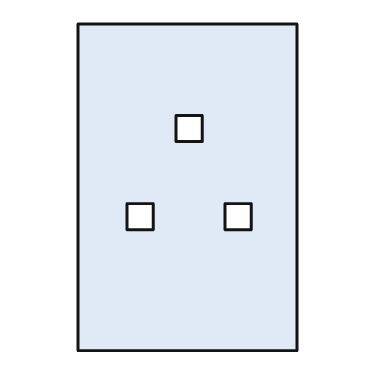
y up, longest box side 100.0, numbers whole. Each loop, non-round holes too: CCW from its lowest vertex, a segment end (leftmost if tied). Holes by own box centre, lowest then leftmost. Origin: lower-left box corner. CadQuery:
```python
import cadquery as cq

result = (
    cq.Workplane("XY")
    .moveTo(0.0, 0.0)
    .lineTo(67.0, 0.0)
    .lineTo(67.0, 100.0)
    .lineTo(0.0, 100.0)
    .close()
    .moveTo(15.0, 37.0)
    .lineTo(23.0, 37.0)
    .lineTo(23.0, 45.0)
    .lineTo(15.0, 45.0)
    .close()
    .moveTo(45.0, 37.0)
    .lineTo(53.0, 37.0)
    .lineTo(53.0, 45.0)
    .lineTo(45.0, 45.0)
    .close()
    .moveTo(30.0, 64.0)
    .lineTo(38.0, 64.0)
    .lineTo(38.0, 72.0)
    .lineTo(30.0, 72.0)
    .close()
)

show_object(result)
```